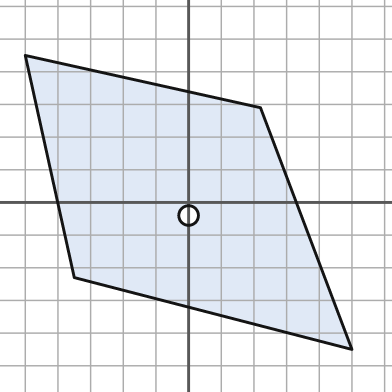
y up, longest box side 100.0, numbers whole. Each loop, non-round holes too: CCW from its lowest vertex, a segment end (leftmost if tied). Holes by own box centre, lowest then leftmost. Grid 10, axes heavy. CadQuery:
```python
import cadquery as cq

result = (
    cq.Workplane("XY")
    .moveTo(50.0, -45.0)
    .lineTo(22.0, 29.0)
    .lineTo(-50.0, 45.0)
    .lineTo(-35.0, -23.0)
    .close()
    .moveTo(0.0, -4.0)
    .circle(3.0)
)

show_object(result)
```